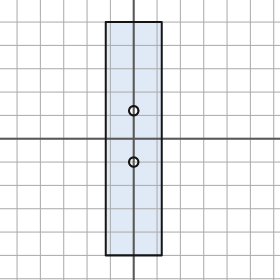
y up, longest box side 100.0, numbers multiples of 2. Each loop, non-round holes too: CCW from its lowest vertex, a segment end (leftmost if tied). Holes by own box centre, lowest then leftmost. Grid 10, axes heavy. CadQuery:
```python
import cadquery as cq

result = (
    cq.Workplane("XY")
    .moveTo(-12.0, -50.0)
    .lineTo(12.0, -50.0)
    .lineTo(12.0, 50.0)
    .lineTo(-12.0, 50.0)
    .close()
    .moveTo(0.0, -10.0)
    .circle(2.0)
    .moveTo(0.0, 12.0)
    .circle(2.0)
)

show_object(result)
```